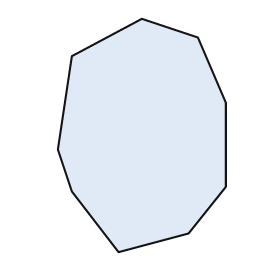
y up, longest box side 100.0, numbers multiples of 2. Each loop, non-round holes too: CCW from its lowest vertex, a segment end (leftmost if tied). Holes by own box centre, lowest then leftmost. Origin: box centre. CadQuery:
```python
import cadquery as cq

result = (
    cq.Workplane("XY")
    .moveTo(-10.0, -50.0)
    .lineTo(20.0, -42.0)
    .lineTo(36.0, -22.0)
    .lineTo(36.0, 14.0)
    .lineTo(24.0, 42.0)
    .lineTo(0.0, 50.0)
    .lineTo(-30.0, 34.0)
    .lineTo(-36.0, -6.0)
    .lineTo(-30.0, -24.0)
    .close()
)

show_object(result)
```